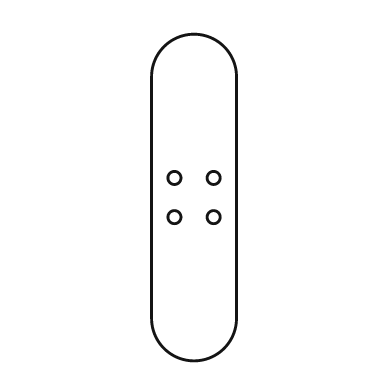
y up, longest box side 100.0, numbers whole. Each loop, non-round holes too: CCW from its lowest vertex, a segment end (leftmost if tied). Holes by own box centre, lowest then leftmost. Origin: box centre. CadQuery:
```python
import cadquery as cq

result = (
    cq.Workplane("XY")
    .moveTo(-13.0, -37.0)
    .threePointArc((0.0, -50.0), (13.0, -37.0))
    .lineTo(13.0, 37.0)
    .threePointArc((0.0, 50.0), (-13.0, 37.0))
    .close()
    .moveTo(-6.0, -6.0)
    .circle(2.0)
    .moveTo(6.0, -6.0)
    .circle(2.0)
    .moveTo(-6.0, 6.0)
    .circle(2.0)
    .moveTo(6.0, 6.0)
    .circle(2.0)
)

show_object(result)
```